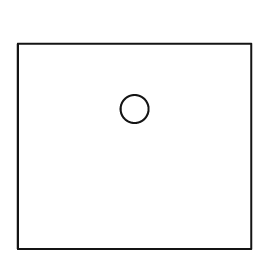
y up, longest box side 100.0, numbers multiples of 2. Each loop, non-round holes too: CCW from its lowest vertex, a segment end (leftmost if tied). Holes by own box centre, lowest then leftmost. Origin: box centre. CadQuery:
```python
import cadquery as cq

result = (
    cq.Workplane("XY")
    .moveTo(-50.0, -44.0)
    .lineTo(50.0, -44.0)
    .lineTo(50.0, 44.0)
    .lineTo(-50.0, 44.0)
    .close()
    .moveTo(0.0, 16.0)
    .circle(6.0)
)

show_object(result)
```